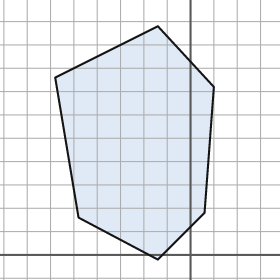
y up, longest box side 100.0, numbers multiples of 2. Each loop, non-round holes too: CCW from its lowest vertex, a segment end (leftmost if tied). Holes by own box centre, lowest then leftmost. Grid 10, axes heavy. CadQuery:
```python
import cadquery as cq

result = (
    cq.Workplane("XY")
    .moveTo(-14.0, -2.0)
    .lineTo(6.0, 18.0)
    .lineTo(10.0, 72.0)
    .lineTo(-14.0, 98.0)
    .lineTo(-58.0, 76.0)
    .lineTo(-48.0, 16.0)
    .close()
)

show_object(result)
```